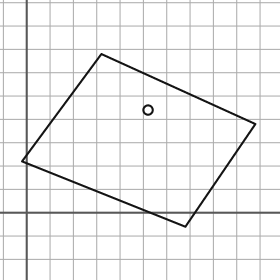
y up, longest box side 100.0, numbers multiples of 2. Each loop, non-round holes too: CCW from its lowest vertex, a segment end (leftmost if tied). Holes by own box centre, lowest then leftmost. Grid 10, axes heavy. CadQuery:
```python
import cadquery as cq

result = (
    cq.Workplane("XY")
    .moveTo(68.0, -6.0)
    .lineTo(98.0, 38.0)
    .lineTo(32.0, 68.0)
    .lineTo(-2.0, 22.0)
    .close()
    .moveTo(52.0, 44.0)
    .circle(2.0)
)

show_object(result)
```